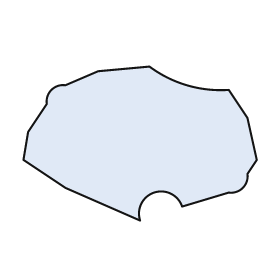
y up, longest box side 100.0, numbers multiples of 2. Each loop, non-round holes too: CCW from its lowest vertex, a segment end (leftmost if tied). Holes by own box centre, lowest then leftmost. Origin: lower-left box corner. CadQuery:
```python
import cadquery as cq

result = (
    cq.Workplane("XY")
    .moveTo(50.0, 0.0)
    .threePointArc((56.0, 12.0), (68.0, 6.0))
    .lineTo(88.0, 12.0)
    .threePointArc((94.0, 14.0), (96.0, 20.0))
    .lineTo(100.0, 26.0)
    .lineTo(96.0, 44.0)
    .lineTo(88.0, 56.0)
    .threePointArc((70.0, 58.0), (54.0, 66.0))
    .lineTo(32.0, 64.0)
    .lineTo(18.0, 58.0)
    .threePointArc((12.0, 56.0), (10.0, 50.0))
    .lineTo(2.0, 38.0)
    .lineTo(0.0, 26.0)
    .lineTo(18.0, 14.0)
    .close()
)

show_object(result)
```